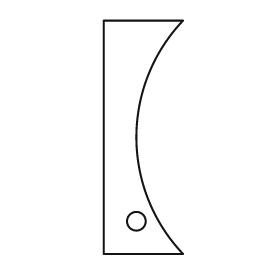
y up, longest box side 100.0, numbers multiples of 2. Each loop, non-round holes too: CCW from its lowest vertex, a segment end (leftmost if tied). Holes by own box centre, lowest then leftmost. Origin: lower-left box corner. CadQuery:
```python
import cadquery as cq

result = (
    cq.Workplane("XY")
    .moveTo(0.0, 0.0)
    .lineTo(34.0, 0.0)
    .threePointArc((14.0, 50.0), (34.0, 100.0))
    .lineTo(0.0, 100.0)
    .close()
    .moveTo(14.0, 14.0)
    .circle(4.0)
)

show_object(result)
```